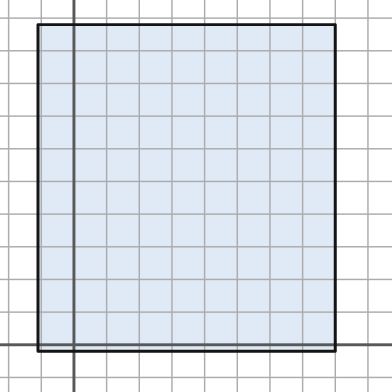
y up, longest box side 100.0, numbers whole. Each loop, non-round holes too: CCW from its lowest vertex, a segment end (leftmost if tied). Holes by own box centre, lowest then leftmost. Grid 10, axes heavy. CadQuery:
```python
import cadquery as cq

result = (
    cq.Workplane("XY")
    .moveTo(-11.0, -2.0)
    .lineTo(80.0, -2.0)
    .lineTo(80.0, 98.0)
    .lineTo(-11.0, 98.0)
    .close()
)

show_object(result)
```